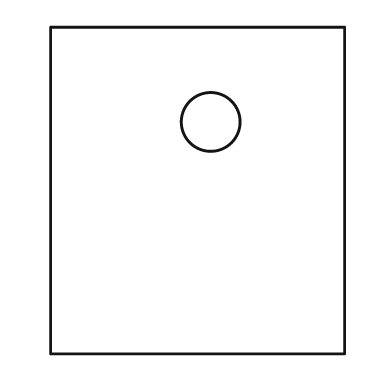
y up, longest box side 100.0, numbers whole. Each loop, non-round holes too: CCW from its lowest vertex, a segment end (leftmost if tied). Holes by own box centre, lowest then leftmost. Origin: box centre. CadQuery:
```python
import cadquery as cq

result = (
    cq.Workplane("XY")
    .moveTo(-45.0, -50.0)
    .lineTo(45.0, -50.0)
    .lineTo(45.0, 50.0)
    .lineTo(-45.0, 50.0)
    .close()
    .moveTo(4.0, 21.0)
    .circle(9.0)
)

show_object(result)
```